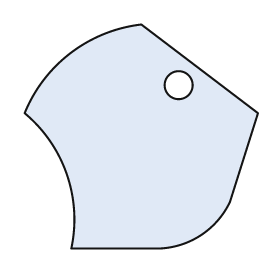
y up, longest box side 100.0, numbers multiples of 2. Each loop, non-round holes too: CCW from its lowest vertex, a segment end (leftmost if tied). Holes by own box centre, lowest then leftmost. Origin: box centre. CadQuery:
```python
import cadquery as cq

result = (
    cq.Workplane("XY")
    .moveTo(-30.0, -48.0)
    .lineTo(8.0, -48.0)
    .threePointArc((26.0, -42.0), (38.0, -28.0))
    .lineTo(50.0, 10.0)
    .lineTo(0.0, 48.0)
    .threePointArc((-30.0, 36.0), (-50.0, 10.0))
    .threePointArc((-32.0, -16.0), (-30.0, -48.0))
    .close()
    .moveTo(16.0, 22.0)
    .circle(6.0)
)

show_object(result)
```